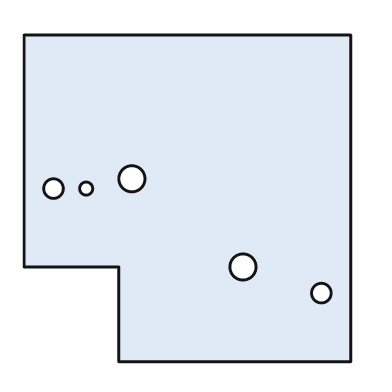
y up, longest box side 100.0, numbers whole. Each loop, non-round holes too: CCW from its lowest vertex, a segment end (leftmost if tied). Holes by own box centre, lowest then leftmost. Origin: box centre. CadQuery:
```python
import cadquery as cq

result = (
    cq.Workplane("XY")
    .moveTo(-21.0, -50.0)
    .lineTo(50.0, -50.0)
    .lineTo(50.0, 50.0)
    .lineTo(-50.0, 50.0)
    .lineTo(-50.0, -21.0)
    .lineTo(-21.0, -21.0)
    .close()
    .moveTo(41.0, -29.0)
    .circle(3.0)
    .moveTo(17.0, -21.0)
    .circle(4.0)
    .moveTo(-41.0, 3.0)
    .circle(3.0)
    .moveTo(-31.0, 3.0)
    .circle(2.0)
    .moveTo(-17.0, 6.0)
    .circle(4.0)
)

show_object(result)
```